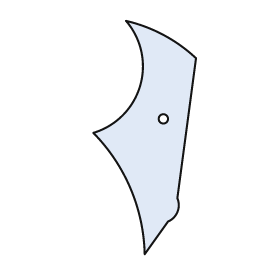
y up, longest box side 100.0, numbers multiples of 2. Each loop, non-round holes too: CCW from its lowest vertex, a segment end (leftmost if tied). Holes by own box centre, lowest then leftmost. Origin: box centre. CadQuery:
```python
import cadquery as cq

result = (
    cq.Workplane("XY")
    .moveTo(0.0, -50.0)
    .lineTo(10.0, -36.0)
    .threePointArc((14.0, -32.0), (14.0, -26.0))
    .lineTo(22.0, 34.0)
    .threePointArc((8.0, 44.0), (-8.0, 50.0))
    .threePointArc((-2.0, 22.0), (-22.0, 2.0))
    .threePointArc((-6.0, -22.0), (0.0, -50.0))
    .close()
    .moveTo(8.0, 8.0)
    .circle(2.0)
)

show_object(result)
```